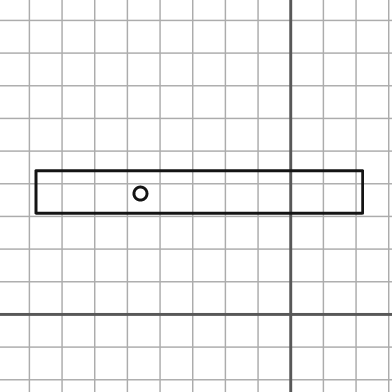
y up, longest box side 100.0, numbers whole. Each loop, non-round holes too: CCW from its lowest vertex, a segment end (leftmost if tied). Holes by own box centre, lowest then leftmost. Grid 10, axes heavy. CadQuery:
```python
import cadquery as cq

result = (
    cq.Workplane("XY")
    .moveTo(-78.0, 31.0)
    .lineTo(22.0, 31.0)
    .lineTo(22.0, 44.0)
    .lineTo(-78.0, 44.0)
    .close()
    .moveTo(-46.0, 37.0)
    .circle(2.0)
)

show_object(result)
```